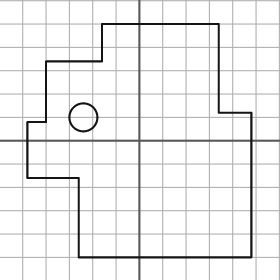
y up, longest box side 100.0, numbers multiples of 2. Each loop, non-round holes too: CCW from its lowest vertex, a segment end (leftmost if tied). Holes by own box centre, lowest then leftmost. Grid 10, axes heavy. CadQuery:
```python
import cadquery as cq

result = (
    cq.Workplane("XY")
    .moveTo(-26.0, -50.0)
    .lineTo(48.0, -50.0)
    .lineTo(48.0, 12.0)
    .lineTo(34.0, 12.0)
    .lineTo(34.0, 50.0)
    .lineTo(-16.0, 50.0)
    .lineTo(-16.0, 34.0)
    .lineTo(-40.0, 34.0)
    .lineTo(-40.0, 8.0)
    .lineTo(-48.0, 8.0)
    .lineTo(-48.0, -16.0)
    .lineTo(-26.0, -16.0)
    .close()
    .moveTo(-24.0, 10.0)
    .circle(6.0)
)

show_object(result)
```